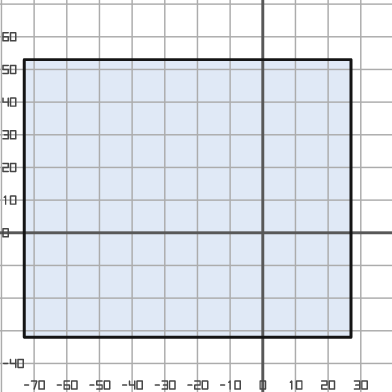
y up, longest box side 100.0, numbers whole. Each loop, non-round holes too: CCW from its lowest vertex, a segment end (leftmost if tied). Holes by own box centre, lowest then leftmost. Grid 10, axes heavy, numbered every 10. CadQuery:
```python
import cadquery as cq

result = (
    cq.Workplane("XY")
    .moveTo(-73.0, -32.0)
    .lineTo(27.0, -32.0)
    .lineTo(27.0, 53.0)
    .lineTo(-73.0, 53.0)
    .close()
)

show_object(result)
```